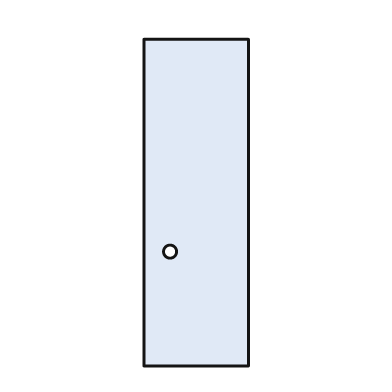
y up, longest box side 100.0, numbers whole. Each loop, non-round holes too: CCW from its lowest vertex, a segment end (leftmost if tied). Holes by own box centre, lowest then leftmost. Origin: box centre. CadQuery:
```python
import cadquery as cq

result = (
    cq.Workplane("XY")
    .moveTo(-16.0, -50.0)
    .lineTo(16.0, -50.0)
    .lineTo(16.0, 50.0)
    .lineTo(-16.0, 50.0)
    .close()
    .moveTo(-8.0, -15.0)
    .circle(2.0)
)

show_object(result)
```